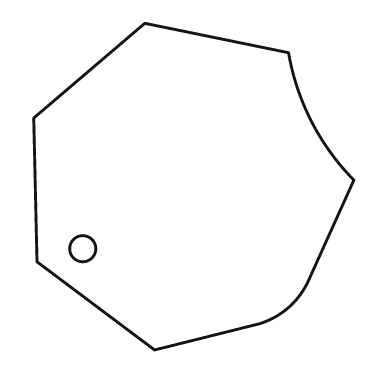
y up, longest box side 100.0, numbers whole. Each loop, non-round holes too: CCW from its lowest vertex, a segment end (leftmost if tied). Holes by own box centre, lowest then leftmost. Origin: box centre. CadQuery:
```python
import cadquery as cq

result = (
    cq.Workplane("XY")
    .moveTo(-12.0, -50.0)
    .lineTo(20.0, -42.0)
    .threePointArc((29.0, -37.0), (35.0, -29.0))
    .lineTo(49.0, 2.0)
    .threePointArc((36.0, 20.0), (29.0, 41.0))
    .lineTo(-15.0, 50.0)
    .lineTo(-49.0, 21.0)
    .lineTo(-48.0, -23.0)
    .close()
    .moveTo(-34.0, -19.0)
    .circle(4.0)
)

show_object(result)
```